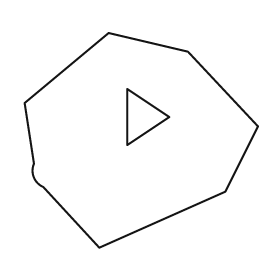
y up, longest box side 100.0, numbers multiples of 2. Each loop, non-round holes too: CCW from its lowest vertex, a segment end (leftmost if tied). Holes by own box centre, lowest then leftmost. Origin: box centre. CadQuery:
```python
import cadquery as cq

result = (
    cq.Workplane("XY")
    .moveTo(-18.0, -46.0)
    .lineTo(36.0, -22.0)
    .lineTo(50.0, 6.0)
    .lineTo(20.0, 38.0)
    .lineTo(-14.0, 46.0)
    .lineTo(-50.0, 16.0)
    .lineTo(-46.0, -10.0)
    .threePointArc((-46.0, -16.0), (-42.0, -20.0))
    .close()
    .moveTo(-6.0, -2.0)
    .lineTo(12.0, 10.0)
    .lineTo(-6.0, 22.0)
    .close()
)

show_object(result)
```